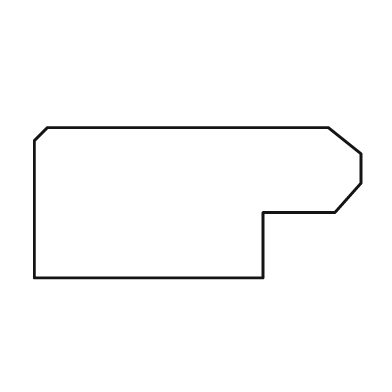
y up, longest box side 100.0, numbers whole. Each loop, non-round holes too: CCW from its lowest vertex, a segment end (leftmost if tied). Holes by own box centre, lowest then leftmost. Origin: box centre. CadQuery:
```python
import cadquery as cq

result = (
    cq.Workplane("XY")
    .moveTo(-50.0, -23.0)
    .lineTo(20.0, -23.0)
    .lineTo(20.0, -3.0)
    .lineTo(42.0, -3.0)
    .lineTo(50.0, 6.0)
    .lineTo(50.0, 15.0)
    .lineTo(40.0, 23.0)
    .lineTo(-46.0, 23.0)
    .lineTo(-50.0, 19.0)
    .close()
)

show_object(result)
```